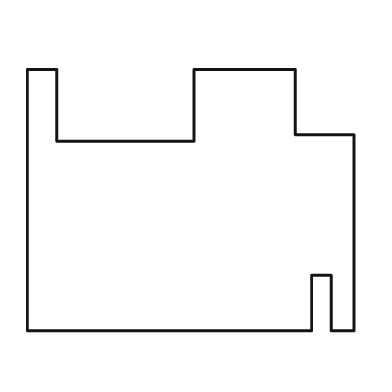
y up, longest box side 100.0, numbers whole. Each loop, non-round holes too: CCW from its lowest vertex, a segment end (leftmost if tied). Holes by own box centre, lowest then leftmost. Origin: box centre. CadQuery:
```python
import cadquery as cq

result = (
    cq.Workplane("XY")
    .moveTo(-50.0, -40.0)
    .lineTo(37.0, -40.0)
    .lineTo(37.0, -23.0)
    .lineTo(43.0, -23.0)
    .lineTo(43.0, -40.0)
    .lineTo(50.0, -40.0)
    .lineTo(50.0, 20.0)
    .lineTo(32.0, 20.0)
    .lineTo(32.0, 40.0)
    .lineTo(1.0, 40.0)
    .lineTo(1.0, 18.0)
    .lineTo(-41.0, 18.0)
    .lineTo(-41.0, 40.0)
    .lineTo(-50.0, 40.0)
    .close()
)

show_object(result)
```